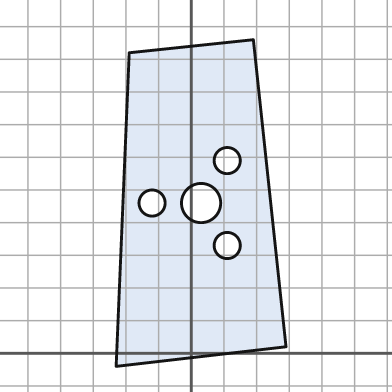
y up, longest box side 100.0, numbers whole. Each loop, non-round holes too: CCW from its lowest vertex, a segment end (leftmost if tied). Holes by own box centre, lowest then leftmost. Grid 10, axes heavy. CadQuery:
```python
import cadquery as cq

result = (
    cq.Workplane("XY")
    .moveTo(-23.0, -4.0)
    .lineTo(29.0, 2.0)
    .lineTo(19.0, 96.0)
    .lineTo(-19.0, 92.0)
    .close()
    .moveTo(11.0, 33.0)
    .circle(4.0)
    .moveTo(-12.0, 46.0)
    .circle(4.0)
    .moveTo(3.0, 46.0)
    .circle(6.0)
    .moveTo(11.0, 59.0)
    .circle(4.0)
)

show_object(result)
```